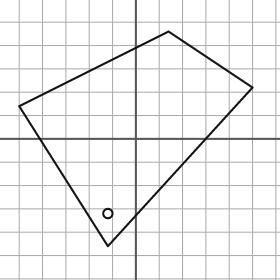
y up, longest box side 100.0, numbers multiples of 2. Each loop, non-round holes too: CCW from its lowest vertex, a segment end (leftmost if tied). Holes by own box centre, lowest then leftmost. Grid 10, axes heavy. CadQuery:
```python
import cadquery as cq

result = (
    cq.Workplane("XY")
    .moveTo(-12.0, -46.0)
    .lineTo(50.0, 22.0)
    .lineTo(14.0, 46.0)
    .lineTo(-50.0, 14.0)
    .close()
    .moveTo(-12.0, -32.0)
    .circle(2.0)
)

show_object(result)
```